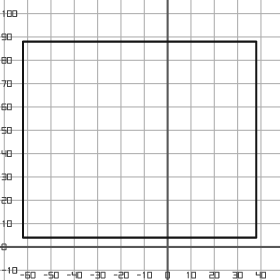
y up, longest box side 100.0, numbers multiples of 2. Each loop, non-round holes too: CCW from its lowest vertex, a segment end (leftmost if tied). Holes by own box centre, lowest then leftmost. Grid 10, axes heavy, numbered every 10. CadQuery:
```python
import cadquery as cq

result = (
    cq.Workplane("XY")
    .moveTo(-62.0, 4.0)
    .lineTo(38.0, 4.0)
    .lineTo(38.0, 88.0)
    .lineTo(-62.0, 88.0)
    .close()
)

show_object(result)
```